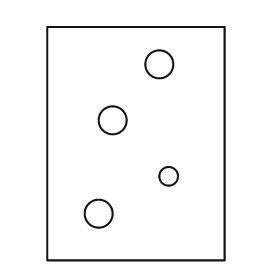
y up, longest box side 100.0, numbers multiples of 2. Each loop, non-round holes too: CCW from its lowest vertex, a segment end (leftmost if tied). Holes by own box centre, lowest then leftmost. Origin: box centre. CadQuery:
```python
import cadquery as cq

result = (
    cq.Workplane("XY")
    .moveTo(-38.0, -50.0)
    .lineTo(38.0, -50.0)
    .lineTo(38.0, 50.0)
    .lineTo(-38.0, 50.0)
    .close()
    .moveTo(-16.0, -30.0)
    .circle(6.0)
    .moveTo(14.0, -14.0)
    .circle(4.0)
    .moveTo(-10.0, 10.0)
    .circle(6.0)
    .moveTo(10.0, 34.0)
    .circle(6.0)
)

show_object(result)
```